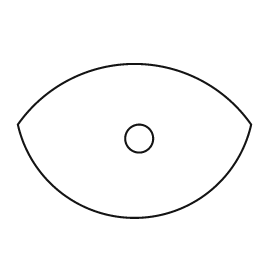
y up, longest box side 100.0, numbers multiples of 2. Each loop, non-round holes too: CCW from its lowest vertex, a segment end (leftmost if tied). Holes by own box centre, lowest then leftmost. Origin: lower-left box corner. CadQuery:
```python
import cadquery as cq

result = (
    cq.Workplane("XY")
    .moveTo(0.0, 40.0)
    .threePointArc((50.0, 0.0), (100.0, 40.0))
    .threePointArc((50.0, 66.0), (0.0, 40.0))
    .close()
    .moveTo(52.0, 34.0)
    .circle(6.0)
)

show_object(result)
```